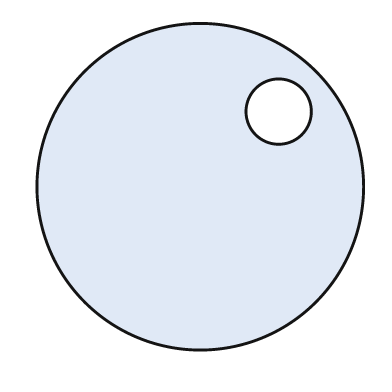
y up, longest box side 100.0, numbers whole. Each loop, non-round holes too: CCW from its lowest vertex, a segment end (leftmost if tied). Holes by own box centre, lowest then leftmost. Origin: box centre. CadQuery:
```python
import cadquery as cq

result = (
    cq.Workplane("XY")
    .moveTo(0.0, 0.0)
    .circle(50.0)
    .moveTo(24.0, 23.0)
    .circle(10.0)
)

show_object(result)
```